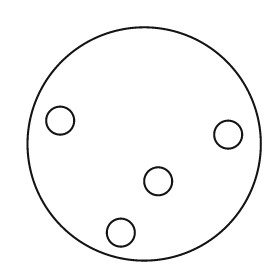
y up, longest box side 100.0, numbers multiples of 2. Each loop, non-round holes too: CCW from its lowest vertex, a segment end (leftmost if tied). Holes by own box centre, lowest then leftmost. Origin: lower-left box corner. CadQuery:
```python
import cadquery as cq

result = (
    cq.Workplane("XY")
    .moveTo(50.0, 50.0)
    .circle(50.0)
    .moveTo(40.0, 12.0)
    .circle(6.0)
    .moveTo(56.0, 34.0)
    .circle(6.0)
    .moveTo(86.0, 54.0)
    .circle(6.0)
    .moveTo(14.0, 60.0)
    .circle(6.0)
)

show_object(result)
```